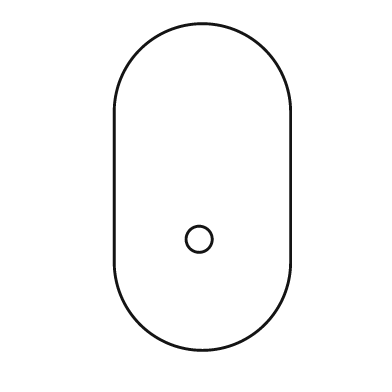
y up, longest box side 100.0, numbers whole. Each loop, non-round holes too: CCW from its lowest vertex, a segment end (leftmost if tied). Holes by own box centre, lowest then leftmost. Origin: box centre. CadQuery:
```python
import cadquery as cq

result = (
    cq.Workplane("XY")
    .moveTo(-27.0, -23.0)
    .threePointArc((0.0, -50.0), (27.0, -23.0))
    .lineTo(27.0, 23.0)
    .threePointArc((0.0, 50.0), (-27.0, 23.0))
    .close()
    .moveTo(-1.0, -16.0)
    .circle(4.0)
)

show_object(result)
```